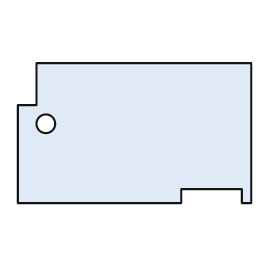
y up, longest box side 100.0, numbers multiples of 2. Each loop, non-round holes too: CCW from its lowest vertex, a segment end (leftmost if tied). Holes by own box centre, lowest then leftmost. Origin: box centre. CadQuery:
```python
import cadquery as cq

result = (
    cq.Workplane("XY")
    .moveTo(-50.0, -30.0)
    .lineTo(20.0, -30.0)
    .lineTo(20.0, -24.0)
    .lineTo(46.0, -24.0)
    .lineTo(46.0, -30.0)
    .lineTo(50.0, -30.0)
    .lineTo(50.0, 30.0)
    .lineTo(-42.0, 30.0)
    .lineTo(-42.0, 12.0)
    .lineTo(-50.0, 12.0)
    .close()
    .moveTo(-38.0, 4.0)
    .circle(4.0)
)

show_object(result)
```